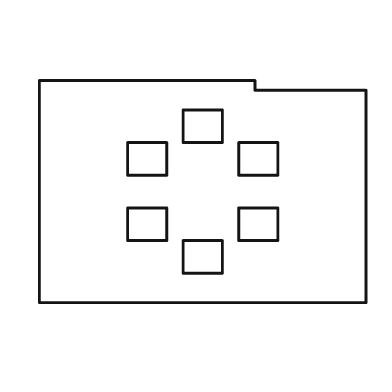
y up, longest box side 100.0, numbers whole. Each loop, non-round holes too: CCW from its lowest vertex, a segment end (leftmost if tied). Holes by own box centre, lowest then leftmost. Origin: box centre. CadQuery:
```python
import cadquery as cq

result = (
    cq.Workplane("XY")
    .moveTo(-50.0, -34.0)
    .lineTo(50.0, -34.0)
    .lineTo(50.0, 31.0)
    .lineTo(16.0, 31.0)
    .lineTo(16.0, 34.0)
    .lineTo(-50.0, 34.0)
    .close()
    .moveTo(-6.0, -25.0)
    .lineTo(6.0, -25.0)
    .lineTo(6.0, -15.0)
    .lineTo(-6.0, -15.0)
    .close()
    .moveTo(-23.0, -15.0)
    .lineTo(-11.0, -15.0)
    .lineTo(-11.0, -5.0)
    .lineTo(-23.0, -5.0)
    .close()
    .moveTo(11.0, -15.0)
    .lineTo(23.0, -15.0)
    .lineTo(23.0, -5.0)
    .lineTo(11.0, -5.0)
    .close()
    .moveTo(-23.0, 5.0)
    .lineTo(-11.0, 5.0)
    .lineTo(-11.0, 15.0)
    .lineTo(-23.0, 15.0)
    .close()
    .moveTo(11.0, 5.0)
    .lineTo(23.0, 5.0)
    .lineTo(23.0, 15.0)
    .lineTo(11.0, 15.0)
    .close()
    .moveTo(-6.0, 15.0)
    .lineTo(6.0, 15.0)
    .lineTo(6.0, 25.0)
    .lineTo(-6.0, 25.0)
    .close()
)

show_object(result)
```